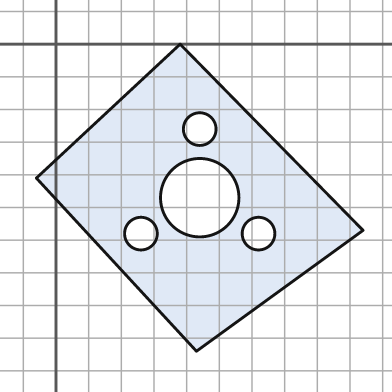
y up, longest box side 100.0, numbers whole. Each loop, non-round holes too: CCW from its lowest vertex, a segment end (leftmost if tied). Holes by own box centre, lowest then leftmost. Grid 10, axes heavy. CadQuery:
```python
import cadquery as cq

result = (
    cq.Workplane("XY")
    .moveTo(43.0, -94.0)
    .lineTo(94.0, -57.0)
    .lineTo(38.0, 0.0)
    .lineTo(-6.0, -41.0)
    .close()
    .moveTo(26.0, -58.0)
    .circle(5.0)
    .moveTo(62.0, -58.0)
    .circle(5.0)
    .moveTo(44.0, -47.0)
    .circle(12.0)
    .moveTo(44.0, -26.0)
    .circle(5.0)
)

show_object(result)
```